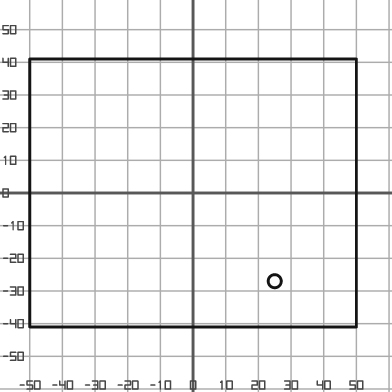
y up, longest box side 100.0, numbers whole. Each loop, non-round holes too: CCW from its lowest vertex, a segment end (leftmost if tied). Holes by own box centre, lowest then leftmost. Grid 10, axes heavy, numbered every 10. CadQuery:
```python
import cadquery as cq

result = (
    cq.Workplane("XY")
    .moveTo(-50.0, -41.0)
    .lineTo(50.0, -41.0)
    .lineTo(50.0, 41.0)
    .lineTo(-50.0, 41.0)
    .close()
    .moveTo(25.0, -27.0)
    .circle(2.0)
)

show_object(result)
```